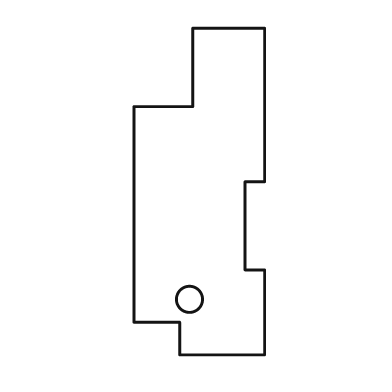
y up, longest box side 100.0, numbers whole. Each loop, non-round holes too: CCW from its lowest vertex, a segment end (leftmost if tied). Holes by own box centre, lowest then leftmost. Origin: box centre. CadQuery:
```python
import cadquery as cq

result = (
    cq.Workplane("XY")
    .moveTo(-6.0, -50.0)
    .lineTo(20.0, -50.0)
    .lineTo(20.0, -24.0)
    .lineTo(14.0, -24.0)
    .lineTo(14.0, 3.0)
    .lineTo(20.0, 3.0)
    .lineTo(20.0, 50.0)
    .lineTo(-2.0, 50.0)
    .lineTo(-2.0, 26.0)
    .lineTo(-20.0, 26.0)
    .lineTo(-20.0, -40.0)
    .lineTo(-6.0, -40.0)
    .close()
    .moveTo(-3.0, -33.0)
    .circle(4.0)
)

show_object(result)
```